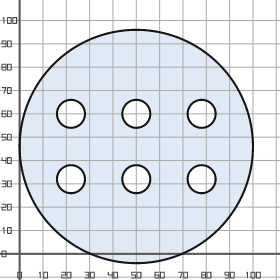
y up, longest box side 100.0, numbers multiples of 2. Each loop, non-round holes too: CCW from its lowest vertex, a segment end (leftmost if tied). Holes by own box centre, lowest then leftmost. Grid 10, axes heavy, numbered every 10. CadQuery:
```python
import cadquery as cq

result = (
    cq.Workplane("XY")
    .moveTo(50.0, 46.0)
    .circle(50.0)
    .moveTo(22.0, 32.0)
    .circle(6.0)
    .moveTo(50.0, 32.0)
    .circle(6.0)
    .moveTo(78.0, 32.0)
    .circle(6.0)
    .moveTo(22.0, 60.0)
    .circle(6.0)
    .moveTo(50.0, 60.0)
    .circle(6.0)
    .moveTo(78.0, 60.0)
    .circle(6.0)
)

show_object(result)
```